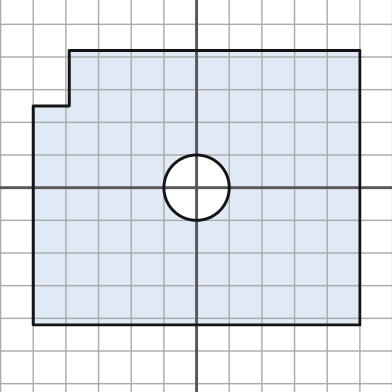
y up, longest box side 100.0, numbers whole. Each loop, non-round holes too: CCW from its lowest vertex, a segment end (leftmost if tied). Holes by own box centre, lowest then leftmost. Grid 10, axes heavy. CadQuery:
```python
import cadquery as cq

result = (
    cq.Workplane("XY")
    .moveTo(-50.0, -42.0)
    .lineTo(50.0, -42.0)
    .lineTo(50.0, 42.0)
    .lineTo(-39.0, 42.0)
    .lineTo(-39.0, 25.0)
    .lineTo(-50.0, 25.0)
    .close()
    .moveTo(0.0, 0.0)
    .circle(10.0)
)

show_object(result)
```